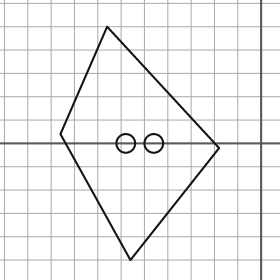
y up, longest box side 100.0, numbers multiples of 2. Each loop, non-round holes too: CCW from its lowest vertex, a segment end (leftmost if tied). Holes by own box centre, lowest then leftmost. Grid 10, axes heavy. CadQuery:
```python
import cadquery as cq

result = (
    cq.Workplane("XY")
    .moveTo(-56.0, -50.0)
    .lineTo(-18.0, -2.0)
    .lineTo(-66.0, 50.0)
    .lineTo(-86.0, 4.0)
    .close()
    .moveTo(-58.0, 0.0)
    .circle(4.0)
    .moveTo(-46.0, 0.0)
    .circle(4.0)
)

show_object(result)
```